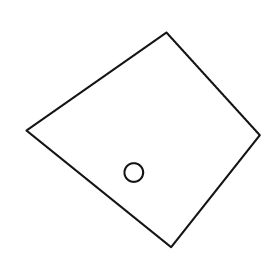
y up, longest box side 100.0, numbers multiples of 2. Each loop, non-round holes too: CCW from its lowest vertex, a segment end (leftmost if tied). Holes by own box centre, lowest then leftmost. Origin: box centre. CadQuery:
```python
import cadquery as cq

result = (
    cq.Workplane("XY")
    .moveTo(12.0, -46.0)
    .lineTo(50.0, 2.0)
    .lineTo(10.0, 46.0)
    .lineTo(-50.0, 4.0)
    .close()
    .moveTo(-4.0, -14.0)
    .circle(4.0)
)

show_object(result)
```